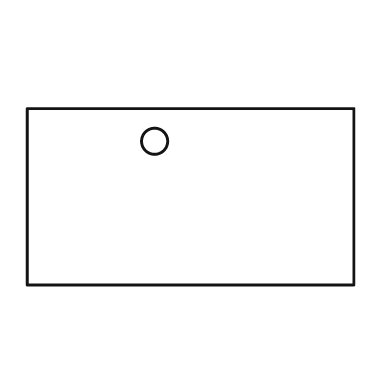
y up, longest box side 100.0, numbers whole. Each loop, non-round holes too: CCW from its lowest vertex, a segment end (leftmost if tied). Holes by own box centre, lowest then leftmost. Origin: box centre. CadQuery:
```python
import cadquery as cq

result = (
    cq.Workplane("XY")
    .moveTo(-50.0, -27.0)
    .lineTo(50.0, -27.0)
    .lineTo(50.0, 27.0)
    .lineTo(-50.0, 27.0)
    .close()
    .moveTo(-11.0, 17.0)
    .circle(4.0)
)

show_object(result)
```